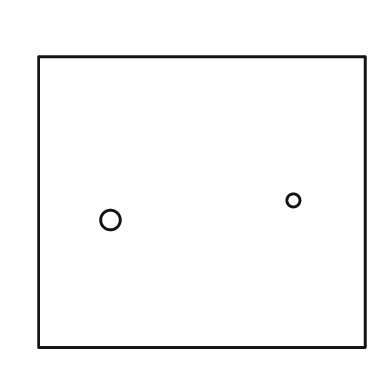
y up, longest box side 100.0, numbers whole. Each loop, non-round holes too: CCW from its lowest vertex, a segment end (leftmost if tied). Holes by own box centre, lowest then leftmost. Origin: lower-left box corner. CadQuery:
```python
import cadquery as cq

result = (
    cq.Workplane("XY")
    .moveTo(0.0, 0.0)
    .lineTo(100.0, 0.0)
    .lineTo(100.0, 89.0)
    .lineTo(0.0, 89.0)
    .close()
    .moveTo(22.0, 39.0)
    .circle(3.0)
    .moveTo(78.0, 45.0)
    .circle(2.0)
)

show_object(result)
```